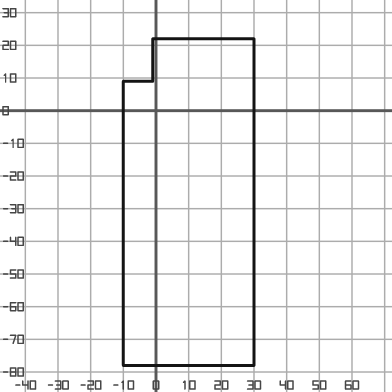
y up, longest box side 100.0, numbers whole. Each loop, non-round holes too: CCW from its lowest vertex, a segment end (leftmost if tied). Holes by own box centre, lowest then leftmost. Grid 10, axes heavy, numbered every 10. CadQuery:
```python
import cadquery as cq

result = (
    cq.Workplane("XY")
    .moveTo(-10.0, -78.0)
    .lineTo(30.0, -78.0)
    .lineTo(30.0, 22.0)
    .lineTo(-1.0, 22.0)
    .lineTo(-1.0, 9.0)
    .lineTo(-10.0, 9.0)
    .close()
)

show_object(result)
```